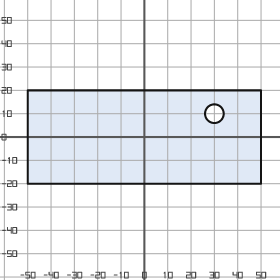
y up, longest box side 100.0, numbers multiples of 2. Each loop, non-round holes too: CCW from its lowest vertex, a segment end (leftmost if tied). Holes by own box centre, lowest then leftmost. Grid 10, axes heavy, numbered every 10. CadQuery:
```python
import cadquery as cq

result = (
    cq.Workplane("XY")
    .moveTo(-50.0, -20.0)
    .lineTo(50.0, -20.0)
    .lineTo(50.0, 20.0)
    .lineTo(-50.0, 20.0)
    .close()
    .moveTo(30.0, 10.0)
    .circle(4.0)
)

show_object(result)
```